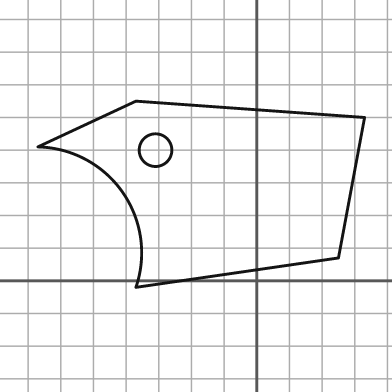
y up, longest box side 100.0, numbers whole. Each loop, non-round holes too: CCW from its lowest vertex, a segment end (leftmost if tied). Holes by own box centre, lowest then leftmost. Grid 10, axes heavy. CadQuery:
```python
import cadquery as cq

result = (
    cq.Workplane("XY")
    .moveTo(-37.0, -2.0)
    .lineTo(25.0, 7.0)
    .lineTo(33.0, 50.0)
    .lineTo(-37.0, 55.0)
    .lineTo(-67.0, 41.0)
    .threePointArc((-41.0, 27.0), (-37.0, -2.0))
    .close()
    .moveTo(-31.0, 40.0)
    .circle(5.0)
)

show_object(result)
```